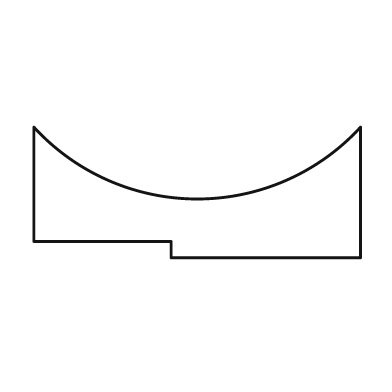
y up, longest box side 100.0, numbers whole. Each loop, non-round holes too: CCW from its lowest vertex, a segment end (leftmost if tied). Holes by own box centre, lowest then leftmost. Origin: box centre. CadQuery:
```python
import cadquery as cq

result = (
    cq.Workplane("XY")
    .moveTo(-8.0, -20.0)
    .lineTo(50.0, -20.0)
    .lineTo(50.0, 20.0)
    .threePointArc((0.0, -2.0), (-50.0, 20.0))
    .lineTo(-50.0, -15.0)
    .lineTo(-8.0, -15.0)
    .close()
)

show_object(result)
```